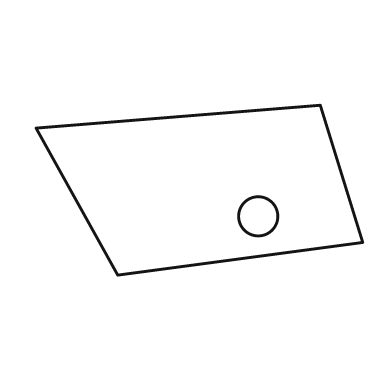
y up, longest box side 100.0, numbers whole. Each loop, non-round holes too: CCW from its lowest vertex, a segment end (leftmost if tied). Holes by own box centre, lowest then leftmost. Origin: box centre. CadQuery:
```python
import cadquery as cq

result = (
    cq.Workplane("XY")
    .moveTo(-25.0, -26.0)
    .lineTo(50.0, -16.0)
    .lineTo(37.0, 26.0)
    .lineTo(-50.0, 19.0)
    .close()
    .moveTo(18.0, -8.0)
    .circle(6.0)
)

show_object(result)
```